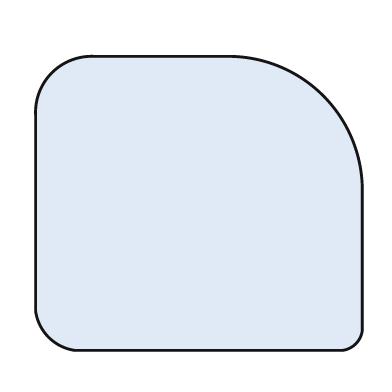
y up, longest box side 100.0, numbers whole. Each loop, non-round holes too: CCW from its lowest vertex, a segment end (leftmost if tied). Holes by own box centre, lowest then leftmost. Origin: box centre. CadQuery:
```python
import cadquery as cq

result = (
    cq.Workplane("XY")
    .moveTo(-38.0, -45.0)
    .lineTo(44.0, -45.0)
    .threePointArc((48.0, -43.0), (50.0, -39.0))
    .lineTo(50.0, 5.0)
    .threePointArc((38.0, 33.0), (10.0, 45.0))
    .lineTo(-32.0, 45.0)
    .threePointArc((-45.0, 40.0), (-50.0, 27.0))
    .lineTo(-50.0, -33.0)
    .threePointArc((-46.0, -41.0), (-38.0, -45.0))
    .close()
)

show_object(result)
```